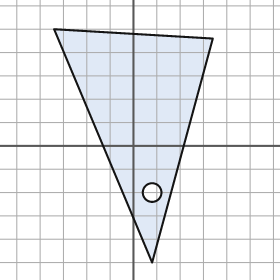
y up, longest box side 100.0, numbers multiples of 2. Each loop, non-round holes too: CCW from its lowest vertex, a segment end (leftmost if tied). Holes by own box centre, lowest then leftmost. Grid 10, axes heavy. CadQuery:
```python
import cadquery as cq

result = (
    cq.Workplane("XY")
    .moveTo(8.0, -50.0)
    .lineTo(34.0, 46.0)
    .lineTo(-34.0, 50.0)
    .close()
    .moveTo(8.0, -20.0)
    .circle(4.0)
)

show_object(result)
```